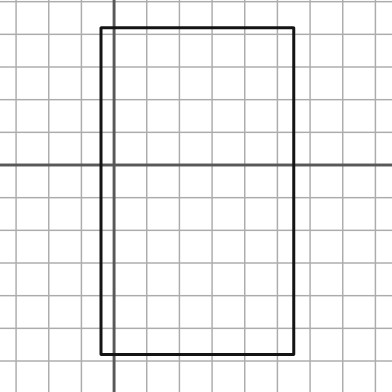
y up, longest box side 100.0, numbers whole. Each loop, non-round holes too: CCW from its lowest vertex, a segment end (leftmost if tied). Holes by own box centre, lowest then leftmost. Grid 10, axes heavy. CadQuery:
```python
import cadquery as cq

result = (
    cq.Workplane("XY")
    .moveTo(-4.0, -58.0)
    .lineTo(55.0, -58.0)
    .lineTo(55.0, 42.0)
    .lineTo(-4.0, 42.0)
    .close()
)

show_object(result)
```